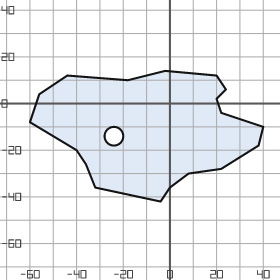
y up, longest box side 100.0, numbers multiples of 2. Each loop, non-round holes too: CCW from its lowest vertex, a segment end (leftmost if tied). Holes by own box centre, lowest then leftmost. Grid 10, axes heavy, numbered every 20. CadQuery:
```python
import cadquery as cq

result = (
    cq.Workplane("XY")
    .moveTo(-4.0, -42.0)
    .lineTo(0.0, -36.0)
    .lineTo(8.0, -30.0)
    .lineTo(22.0, -28.0)
    .lineTo(38.0, -18.0)
    .lineTo(40.0, -10.0)
    .lineTo(22.0, -4.0)
    .lineTo(20.0, 2.0)
    .lineTo(24.0, 6.0)
    .lineTo(20.0, 12.0)
    .lineTo(-2.0, 14.0)
    .lineTo(-18.0, 10.0)
    .lineTo(-44.0, 12.0)
    .lineTo(-56.0, 4.0)
    .lineTo(-60.0, -8.0)
    .lineTo(-40.0, -20.0)
    .lineTo(-36.0, -26.0)
    .lineTo(-32.0, -36.0)
    .close()
    .moveTo(-24.0, -14.0)
    .circle(4.0)
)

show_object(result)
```